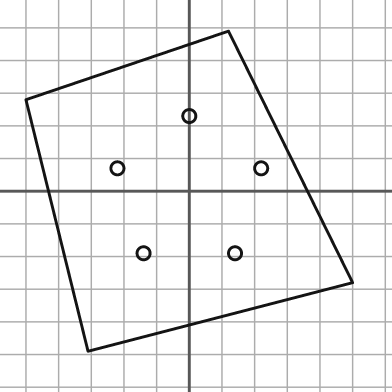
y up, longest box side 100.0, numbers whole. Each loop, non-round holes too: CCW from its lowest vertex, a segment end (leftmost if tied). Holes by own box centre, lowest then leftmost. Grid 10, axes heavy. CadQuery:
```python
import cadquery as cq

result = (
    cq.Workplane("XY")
    .moveTo(-31.0, -49.0)
    .lineTo(50.0, -28.0)
    .lineTo(12.0, 49.0)
    .lineTo(-50.0, 28.0)
    .close()
    .moveTo(-14.0, -19.0)
    .circle(2.0)
    .moveTo(14.0, -19.0)
    .circle(2.0)
    .moveTo(-22.0, 7.0)
    .circle(2.0)
    .moveTo(22.0, 7.0)
    .circle(2.0)
    .moveTo(0.0, 23.0)
    .circle(2.0)
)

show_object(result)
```